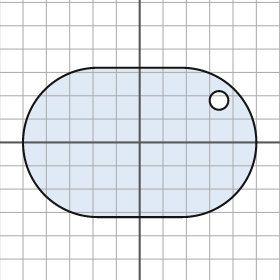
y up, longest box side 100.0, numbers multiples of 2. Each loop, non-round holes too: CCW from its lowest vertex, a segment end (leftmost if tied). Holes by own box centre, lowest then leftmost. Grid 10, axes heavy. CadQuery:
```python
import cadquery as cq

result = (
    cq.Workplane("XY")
    .moveTo(-18.0, -32.0)
    .lineTo(18.0, -32.0)
    .threePointArc((50.0, 0.0), (18.0, 32.0))
    .lineTo(-18.0, 32.0)
    .threePointArc((-50.0, 0.0), (-18.0, -32.0))
    .close()
    .moveTo(34.0, 18.0)
    .circle(4.0)
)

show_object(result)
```